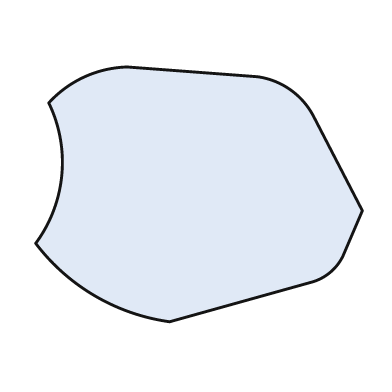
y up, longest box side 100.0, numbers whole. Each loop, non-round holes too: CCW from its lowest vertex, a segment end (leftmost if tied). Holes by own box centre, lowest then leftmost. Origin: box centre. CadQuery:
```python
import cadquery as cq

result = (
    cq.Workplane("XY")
    .moveTo(-9.0, -39.0)
    .lineTo(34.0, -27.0)
    .threePointArc((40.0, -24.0), (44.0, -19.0))
    .lineTo(50.0, -5.0)
    .lineTo(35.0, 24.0)
    .threePointArc((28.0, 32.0), (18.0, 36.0))
    .lineTo(-22.0, 39.0)
    .threePointArc((-35.0, 36.0), (-46.0, 28.0))
    .threePointArc((-42.0, 6.0), (-50.0, -15.0))
    .threePointArc((-32.0, -31.0), (-9.0, -39.0))
    .close()
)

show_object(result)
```